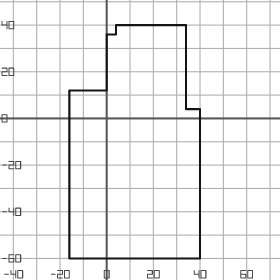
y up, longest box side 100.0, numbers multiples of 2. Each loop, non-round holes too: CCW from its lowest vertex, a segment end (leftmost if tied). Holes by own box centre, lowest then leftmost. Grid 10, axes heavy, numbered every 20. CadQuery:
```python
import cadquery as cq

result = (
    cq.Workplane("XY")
    .moveTo(-16.0, -60.0)
    .lineTo(40.0, -60.0)
    .lineTo(40.0, 4.0)
    .lineTo(34.0, 4.0)
    .lineTo(34.0, 40.0)
    .lineTo(4.0, 40.0)
    .lineTo(4.0, 36.0)
    .lineTo(0.0, 36.0)
    .lineTo(0.0, 12.0)
    .lineTo(-16.0, 12.0)
    .close()
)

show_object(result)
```